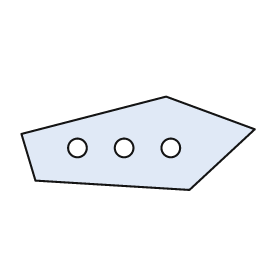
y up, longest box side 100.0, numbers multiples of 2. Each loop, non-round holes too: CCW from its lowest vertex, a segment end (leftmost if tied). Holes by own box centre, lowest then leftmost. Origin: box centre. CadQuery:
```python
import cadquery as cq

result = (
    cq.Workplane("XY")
    .moveTo(22.0, -20.0)
    .lineTo(50.0, 6.0)
    .lineTo(12.0, 20.0)
    .lineTo(-50.0, 4.0)
    .lineTo(-44.0, -16.0)
    .close()
    .moveTo(-26.0, -2.0)
    .circle(4.0)
    .moveTo(-6.0, -2.0)
    .circle(4.0)
    .moveTo(14.0, -2.0)
    .circle(4.0)
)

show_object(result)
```